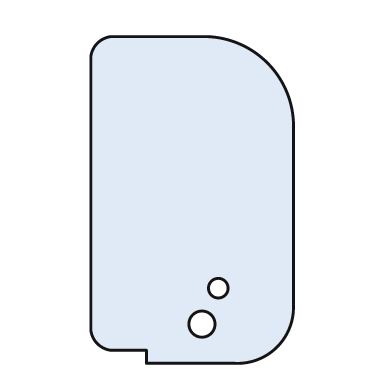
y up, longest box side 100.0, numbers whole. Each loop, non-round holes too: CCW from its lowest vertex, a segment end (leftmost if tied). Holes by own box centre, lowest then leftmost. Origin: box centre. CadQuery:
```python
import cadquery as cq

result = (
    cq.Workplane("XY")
    .moveTo(-14.0, -50.0)
    .lineTo(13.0, -50.0)
    .threePointArc((26.0, -45.0), (31.0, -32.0))
    .lineTo(31.0, 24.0)
    .threePointArc((23.0, 42.0), (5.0, 50.0))
    .lineTo(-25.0, 50.0)
    .threePointArc((-29.0, 48.0), (-31.0, 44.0))
    .lineTo(-31.0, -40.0)
    .threePointArc((-29.0, -44.0), (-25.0, -46.0))
    .lineTo(-14.0, -46.0)
    .close()
    .moveTo(3.0, -38.0)
    .circle(4.0)
    .moveTo(8.0, -27.0)
    .circle(3.0)
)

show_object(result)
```